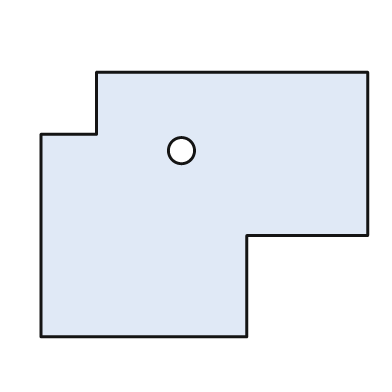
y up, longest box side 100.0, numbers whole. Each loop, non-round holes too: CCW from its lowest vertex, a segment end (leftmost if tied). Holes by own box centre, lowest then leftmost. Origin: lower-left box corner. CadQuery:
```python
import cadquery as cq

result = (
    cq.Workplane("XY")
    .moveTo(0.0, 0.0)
    .lineTo(63.0, 0.0)
    .lineTo(63.0, 31.0)
    .lineTo(100.0, 31.0)
    .lineTo(100.0, 81.0)
    .lineTo(17.0, 81.0)
    .lineTo(17.0, 62.0)
    .lineTo(0.0, 62.0)
    .close()
    .moveTo(43.0, 57.0)
    .circle(4.0)
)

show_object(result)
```